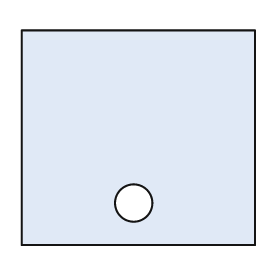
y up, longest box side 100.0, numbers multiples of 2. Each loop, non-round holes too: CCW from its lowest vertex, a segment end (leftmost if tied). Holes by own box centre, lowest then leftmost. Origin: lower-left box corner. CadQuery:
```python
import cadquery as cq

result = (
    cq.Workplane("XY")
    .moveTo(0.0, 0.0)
    .lineTo(100.0, 0.0)
    .lineTo(100.0, 92.0)
    .lineTo(0.0, 92.0)
    .close()
    .moveTo(48.0, 18.0)
    .circle(8.0)
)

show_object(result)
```